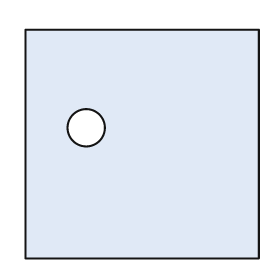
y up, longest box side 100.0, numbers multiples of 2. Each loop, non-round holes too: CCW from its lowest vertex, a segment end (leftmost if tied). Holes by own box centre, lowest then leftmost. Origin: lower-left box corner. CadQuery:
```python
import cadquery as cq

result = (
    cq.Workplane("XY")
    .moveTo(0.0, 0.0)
    .lineTo(100.0, 0.0)
    .lineTo(100.0, 98.0)
    .lineTo(0.0, 98.0)
    .close()
    .moveTo(26.0, 56.0)
    .circle(8.0)
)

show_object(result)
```